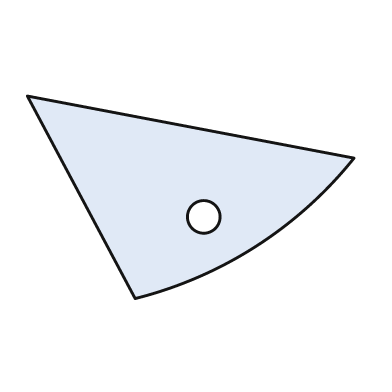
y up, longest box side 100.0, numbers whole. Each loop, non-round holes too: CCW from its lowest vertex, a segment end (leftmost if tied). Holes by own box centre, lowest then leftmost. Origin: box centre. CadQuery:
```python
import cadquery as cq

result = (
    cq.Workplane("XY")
    .moveTo(-17.0, -31.0)
    .threePointArc((20.0, -15.0), (50.0, 12.0))
    .lineTo(-50.0, 31.0)
    .close()
    .moveTo(4.0, -6.0)
    .circle(5.0)
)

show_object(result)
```